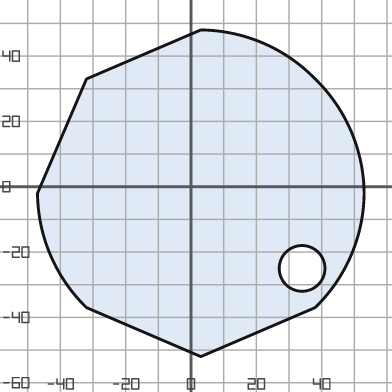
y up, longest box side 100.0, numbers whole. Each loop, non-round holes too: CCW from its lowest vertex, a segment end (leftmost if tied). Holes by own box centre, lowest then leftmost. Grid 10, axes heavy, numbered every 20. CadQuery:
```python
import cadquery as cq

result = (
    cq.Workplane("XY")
    .moveTo(3.0, -52.0)
    .lineTo(38.0, -37.0)
    .threePointArc((49.0, -21.0), (53.0, -2.0))
    .threePointArc((49.0, 17.0), (38.0, 33.0))
    .threePointArc((22.0, 44.0), (3.0, 48.0))
    .lineTo(-32.0, 33.0)
    .lineTo(-47.0, -2.0)
    .threePointArc((-43.0, -21.0), (-32.0, -37.0))
    .close()
    .moveTo(34.0, -25.0)
    .circle(7.0)
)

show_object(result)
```